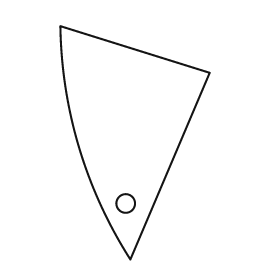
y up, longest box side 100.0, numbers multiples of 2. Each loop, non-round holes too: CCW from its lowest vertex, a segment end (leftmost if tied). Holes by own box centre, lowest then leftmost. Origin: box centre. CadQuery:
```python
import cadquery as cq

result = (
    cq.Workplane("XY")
    .moveTo(-2.0, -50.0)
    .lineTo(32.0, 30.0)
    .lineTo(-32.0, 50.0)
    .threePointArc((-24.0, -2.0), (-2.0, -50.0))
    .close()
    .moveTo(-4.0, -26.0)
    .circle(4.0)
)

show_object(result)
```